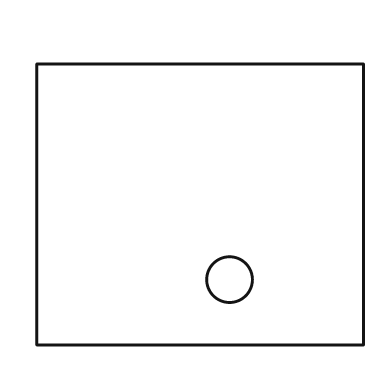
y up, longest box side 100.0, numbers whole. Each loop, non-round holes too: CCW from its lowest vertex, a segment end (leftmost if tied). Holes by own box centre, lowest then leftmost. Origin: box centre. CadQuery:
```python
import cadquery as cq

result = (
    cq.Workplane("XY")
    .moveTo(-50.0, -43.0)
    .lineTo(50.0, -43.0)
    .lineTo(50.0, 43.0)
    .lineTo(-50.0, 43.0)
    .close()
    .moveTo(9.0, -23.0)
    .circle(7.0)
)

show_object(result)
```